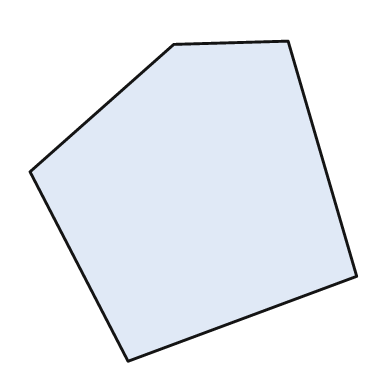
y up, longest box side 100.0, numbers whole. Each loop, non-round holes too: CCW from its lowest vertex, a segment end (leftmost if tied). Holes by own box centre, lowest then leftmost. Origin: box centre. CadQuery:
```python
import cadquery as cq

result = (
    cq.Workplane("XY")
    .moveTo(-20.0, -49.0)
    .lineTo(50.0, -23.0)
    .lineTo(29.0, 49.0)
    .lineTo(-6.0, 48.0)
    .lineTo(-50.0, 9.0)
    .close()
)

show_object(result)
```